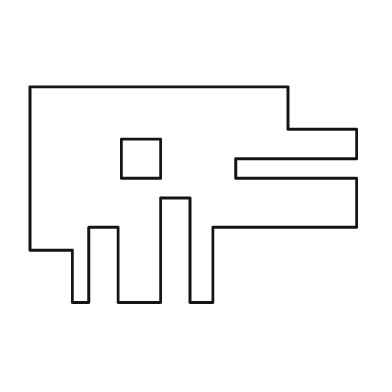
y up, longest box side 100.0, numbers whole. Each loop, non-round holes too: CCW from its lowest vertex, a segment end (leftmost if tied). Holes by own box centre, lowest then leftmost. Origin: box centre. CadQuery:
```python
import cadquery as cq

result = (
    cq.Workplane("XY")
    .moveTo(-37.0, -33.0)
    .lineTo(-32.0, -33.0)
    .lineTo(-32.0, -10.0)
    .lineTo(-23.0, -10.0)
    .lineTo(-23.0, -33.0)
    .lineTo(-10.0, -33.0)
    .lineTo(-10.0, -1.0)
    .lineTo(-1.0, -1.0)
    .lineTo(-1.0, -33.0)
    .lineTo(6.0, -33.0)
    .lineTo(6.0, -10.0)
    .lineTo(50.0, -10.0)
    .lineTo(50.0, 5.0)
    .lineTo(13.0, 5.0)
    .lineTo(13.0, 11.0)
    .lineTo(50.0, 11.0)
    .lineTo(50.0, 20.0)
    .lineTo(29.0, 20.0)
    .lineTo(29.0, 33.0)
    .lineTo(-50.0, 33.0)
    .lineTo(-50.0, -17.0)
    .lineTo(-37.0, -17.0)
    .close()
    .moveTo(-22.0, 5.0)
    .lineTo(-10.0, 5.0)
    .lineTo(-10.0, 17.0)
    .lineTo(-22.0, 17.0)
    .close()
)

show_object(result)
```